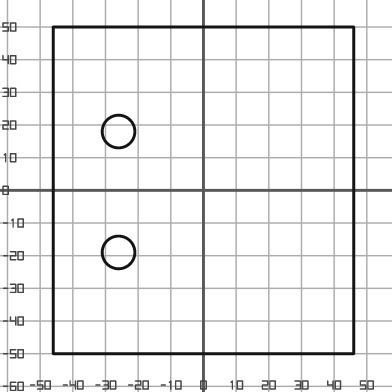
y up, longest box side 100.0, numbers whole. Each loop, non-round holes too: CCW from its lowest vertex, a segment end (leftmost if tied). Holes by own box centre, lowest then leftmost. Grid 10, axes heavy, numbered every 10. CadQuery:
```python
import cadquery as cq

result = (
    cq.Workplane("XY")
    .moveTo(-46.0, -50.0)
    .lineTo(46.0, -50.0)
    .lineTo(46.0, 50.0)
    .lineTo(-46.0, 50.0)
    .close()
    .moveTo(-26.0, -19.0)
    .circle(5.0)
    .moveTo(-26.0, 18.0)
    .circle(5.0)
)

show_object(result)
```